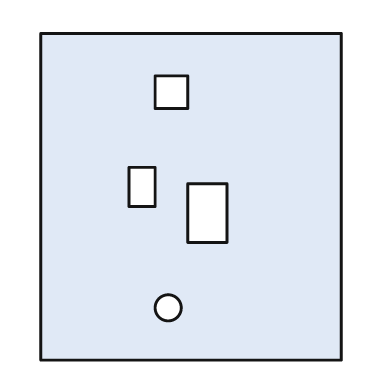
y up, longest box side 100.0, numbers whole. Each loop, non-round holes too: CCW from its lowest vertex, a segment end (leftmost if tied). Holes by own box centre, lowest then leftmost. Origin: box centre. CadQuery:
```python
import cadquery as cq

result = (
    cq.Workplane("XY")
    .moveTo(-46.0, -50.0)
    .lineTo(46.0, -50.0)
    .lineTo(46.0, 50.0)
    .lineTo(-46.0, 50.0)
    .close()
    .moveTo(-7.0, -34.0)
    .circle(4.0)
    .moveTo(-1.0, -14.0)
    .lineTo(11.0, -14.0)
    .lineTo(11.0, 4.0)
    .lineTo(-1.0, 4.0)
    .close()
    .moveTo(-19.0, -3.0)
    .lineTo(-11.0, -3.0)
    .lineTo(-11.0, 9.0)
    .lineTo(-19.0, 9.0)
    .close()
    .moveTo(-11.0, 27.0)
    .lineTo(-1.0, 27.0)
    .lineTo(-1.0, 37.0)
    .lineTo(-11.0, 37.0)
    .close()
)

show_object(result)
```